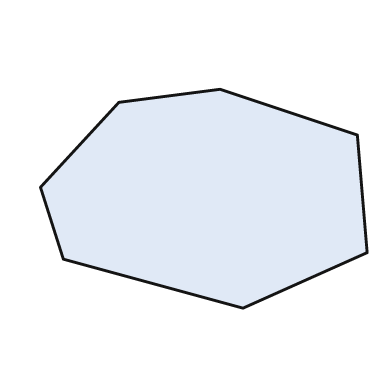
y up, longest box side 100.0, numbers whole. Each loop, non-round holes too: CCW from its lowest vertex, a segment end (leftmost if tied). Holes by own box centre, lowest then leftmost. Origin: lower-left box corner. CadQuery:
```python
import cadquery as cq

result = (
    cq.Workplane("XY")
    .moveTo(62.0, 0.0)
    .lineTo(100.0, 17.0)
    .lineTo(97.0, 53.0)
    .lineTo(55.0, 67.0)
    .lineTo(24.0, 63.0)
    .lineTo(0.0, 37.0)
    .lineTo(7.0, 15.0)
    .close()
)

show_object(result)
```